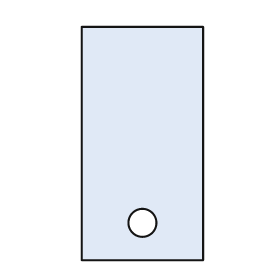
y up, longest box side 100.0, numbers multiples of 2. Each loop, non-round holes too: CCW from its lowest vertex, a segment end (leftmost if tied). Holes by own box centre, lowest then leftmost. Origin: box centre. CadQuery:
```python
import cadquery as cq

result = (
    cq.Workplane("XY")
    .moveTo(-26.0, -50.0)
    .lineTo(26.0, -50.0)
    .lineTo(26.0, 50.0)
    .lineTo(-26.0, 50.0)
    .close()
    .moveTo(0.0, -34.0)
    .circle(6.0)
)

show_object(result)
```